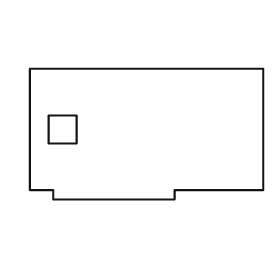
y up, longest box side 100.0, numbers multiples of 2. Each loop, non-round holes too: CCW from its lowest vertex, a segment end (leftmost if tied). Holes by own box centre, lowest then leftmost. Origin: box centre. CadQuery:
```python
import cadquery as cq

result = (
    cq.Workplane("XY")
    .moveTo(-40.0, -28.0)
    .lineTo(12.0, -28.0)
    .lineTo(12.0, -24.0)
    .lineTo(50.0, -24.0)
    .lineTo(50.0, 28.0)
    .lineTo(-50.0, 28.0)
    .lineTo(-50.0, -24.0)
    .lineTo(-40.0, -24.0)
    .close()
    .moveTo(-42.0, -4.0)
    .lineTo(-30.0, -4.0)
    .lineTo(-30.0, 8.0)
    .lineTo(-42.0, 8.0)
    .close()
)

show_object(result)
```